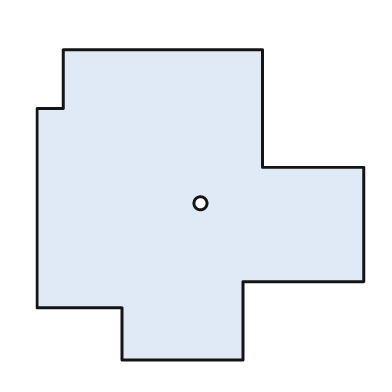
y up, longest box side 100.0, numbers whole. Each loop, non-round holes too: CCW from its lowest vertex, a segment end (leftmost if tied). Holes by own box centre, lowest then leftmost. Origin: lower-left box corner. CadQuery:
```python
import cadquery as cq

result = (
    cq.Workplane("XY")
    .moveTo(26.0, 0.0)
    .lineTo(63.0, 0.0)
    .lineTo(63.0, 24.0)
    .lineTo(100.0, 24.0)
    .lineTo(100.0, 59.0)
    .lineTo(69.0, 59.0)
    .lineTo(69.0, 95.0)
    .lineTo(8.0, 95.0)
    .lineTo(8.0, 77.0)
    .lineTo(0.0, 77.0)
    .lineTo(0.0, 16.0)
    .lineTo(26.0, 16.0)
    .close()
    .moveTo(50.0, 48.0)
    .circle(2.0)
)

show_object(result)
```